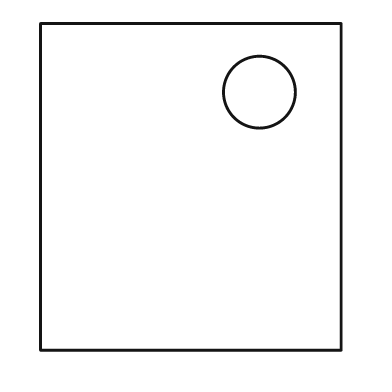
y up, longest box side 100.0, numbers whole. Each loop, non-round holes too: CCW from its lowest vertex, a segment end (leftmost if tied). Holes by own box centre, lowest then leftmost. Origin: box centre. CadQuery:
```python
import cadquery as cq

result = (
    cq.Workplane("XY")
    .moveTo(-46.0, -50.0)
    .lineTo(46.0, -50.0)
    .lineTo(46.0, 50.0)
    .lineTo(-46.0, 50.0)
    .close()
    .moveTo(21.0, 29.0)
    .circle(11.0)
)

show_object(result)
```